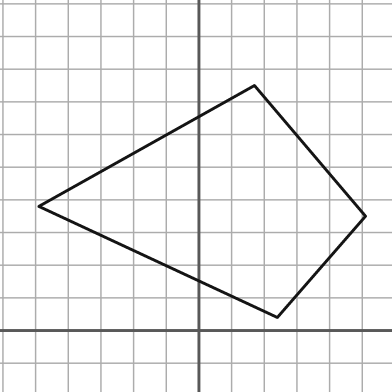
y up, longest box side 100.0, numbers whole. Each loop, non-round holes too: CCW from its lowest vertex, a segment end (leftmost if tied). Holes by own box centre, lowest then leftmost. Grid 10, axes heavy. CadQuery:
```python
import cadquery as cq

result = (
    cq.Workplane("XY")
    .moveTo(24.0, 4.0)
    .lineTo(51.0, 35.0)
    .lineTo(17.0, 75.0)
    .lineTo(-49.0, 38.0)
    .close()
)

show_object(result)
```